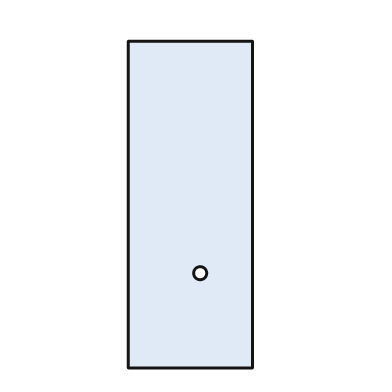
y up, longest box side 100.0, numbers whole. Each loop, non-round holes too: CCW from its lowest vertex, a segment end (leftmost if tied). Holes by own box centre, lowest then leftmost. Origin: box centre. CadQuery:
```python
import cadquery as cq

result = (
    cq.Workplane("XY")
    .moveTo(-19.0, -50.0)
    .lineTo(19.0, -50.0)
    .lineTo(19.0, 50.0)
    .lineTo(-19.0, 50.0)
    .close()
    .moveTo(3.0, -21.0)
    .circle(2.0)
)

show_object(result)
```